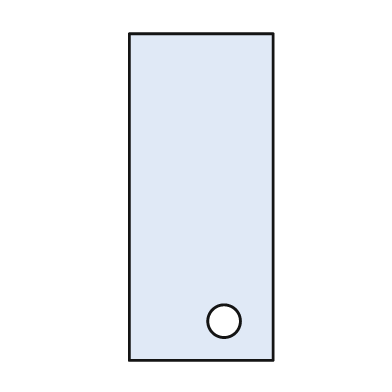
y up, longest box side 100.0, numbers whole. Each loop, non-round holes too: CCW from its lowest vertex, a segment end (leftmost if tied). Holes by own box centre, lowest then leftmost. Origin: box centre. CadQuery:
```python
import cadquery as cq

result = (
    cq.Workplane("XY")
    .moveTo(-22.0, -50.0)
    .lineTo(22.0, -50.0)
    .lineTo(22.0, 50.0)
    .lineTo(-22.0, 50.0)
    .close()
    .moveTo(7.0, -38.0)
    .circle(5.0)
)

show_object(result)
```